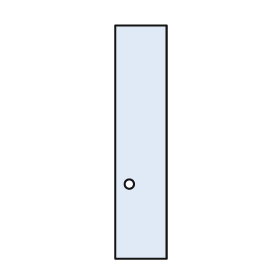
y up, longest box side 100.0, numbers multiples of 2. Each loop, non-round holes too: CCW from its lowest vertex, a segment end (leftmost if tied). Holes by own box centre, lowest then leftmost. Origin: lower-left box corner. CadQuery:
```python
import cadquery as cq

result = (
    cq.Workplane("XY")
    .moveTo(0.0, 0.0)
    .lineTo(22.0, 0.0)
    .lineTo(22.0, 100.0)
    .lineTo(0.0, 100.0)
    .close()
    .moveTo(6.0, 32.0)
    .circle(2.0)
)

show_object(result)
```